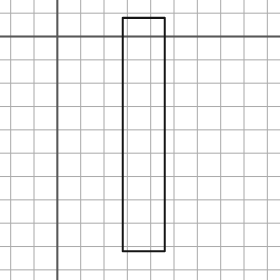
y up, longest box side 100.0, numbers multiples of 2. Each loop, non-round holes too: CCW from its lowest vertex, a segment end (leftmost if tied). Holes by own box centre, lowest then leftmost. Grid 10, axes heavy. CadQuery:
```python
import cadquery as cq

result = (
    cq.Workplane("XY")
    .moveTo(28.0, -92.0)
    .lineTo(46.0, -92.0)
    .lineTo(46.0, 8.0)
    .lineTo(28.0, 8.0)
    .close()
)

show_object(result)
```